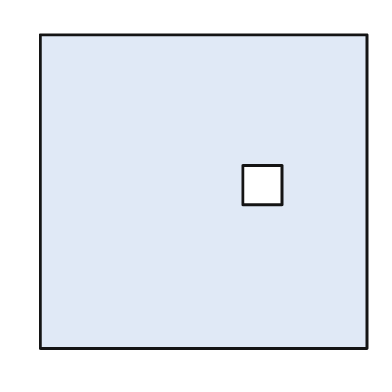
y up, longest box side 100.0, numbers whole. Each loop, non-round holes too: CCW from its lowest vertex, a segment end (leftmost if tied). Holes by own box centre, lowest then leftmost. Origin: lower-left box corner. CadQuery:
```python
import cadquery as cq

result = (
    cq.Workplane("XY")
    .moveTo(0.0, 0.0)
    .lineTo(100.0, 0.0)
    .lineTo(100.0, 96.0)
    .lineTo(0.0, 96.0)
    .close()
    .moveTo(62.0, 44.0)
    .lineTo(74.0, 44.0)
    .lineTo(74.0, 56.0)
    .lineTo(62.0, 56.0)
    .close()
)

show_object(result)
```